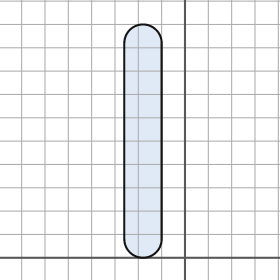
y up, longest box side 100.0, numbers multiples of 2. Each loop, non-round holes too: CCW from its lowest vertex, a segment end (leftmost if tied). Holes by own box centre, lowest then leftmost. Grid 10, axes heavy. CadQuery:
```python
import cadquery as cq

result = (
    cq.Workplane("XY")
    .moveTo(-26.0, 8.0)
    .threePointArc((-18.0, 0.0), (-10.0, 8.0))
    .lineTo(-10.0, 92.0)
    .threePointArc((-18.0, 100.0), (-26.0, 92.0))
    .close()
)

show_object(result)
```